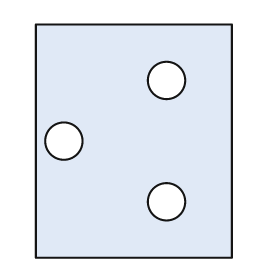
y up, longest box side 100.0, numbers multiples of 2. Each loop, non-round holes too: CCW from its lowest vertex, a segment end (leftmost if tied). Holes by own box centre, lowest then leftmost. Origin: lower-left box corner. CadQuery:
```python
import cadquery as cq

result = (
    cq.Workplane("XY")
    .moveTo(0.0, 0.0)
    .lineTo(84.0, 0.0)
    .lineTo(84.0, 100.0)
    .lineTo(0.0, 100.0)
    .close()
    .moveTo(56.0, 24.0)
    .circle(8.0)
    .moveTo(12.0, 50.0)
    .circle(8.0)
    .moveTo(56.0, 76.0)
    .circle(8.0)
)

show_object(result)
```